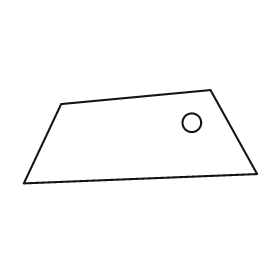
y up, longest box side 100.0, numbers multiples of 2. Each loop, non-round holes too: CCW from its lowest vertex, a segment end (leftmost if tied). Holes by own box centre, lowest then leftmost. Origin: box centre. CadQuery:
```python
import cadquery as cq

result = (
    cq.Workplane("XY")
    .moveTo(-50.0, -20.0)
    .lineTo(50.0, -16.0)
    .lineTo(30.0, 20.0)
    .lineTo(-34.0, 14.0)
    .close()
    .moveTo(22.0, 6.0)
    .circle(4.0)
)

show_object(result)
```